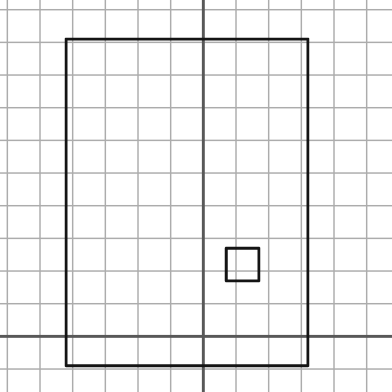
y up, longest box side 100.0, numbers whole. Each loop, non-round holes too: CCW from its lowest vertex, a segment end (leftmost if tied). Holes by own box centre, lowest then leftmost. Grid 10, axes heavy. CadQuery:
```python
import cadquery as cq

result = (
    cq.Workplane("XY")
    .moveTo(-42.0, -9.0)
    .lineTo(32.0, -9.0)
    .lineTo(32.0, 91.0)
    .lineTo(-42.0, 91.0)
    .close()
    .moveTo(7.0, 17.0)
    .lineTo(17.0, 17.0)
    .lineTo(17.0, 27.0)
    .lineTo(7.0, 27.0)
    .close()
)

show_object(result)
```